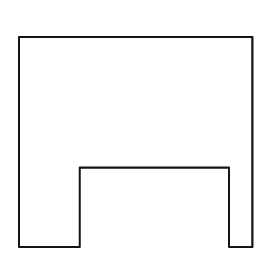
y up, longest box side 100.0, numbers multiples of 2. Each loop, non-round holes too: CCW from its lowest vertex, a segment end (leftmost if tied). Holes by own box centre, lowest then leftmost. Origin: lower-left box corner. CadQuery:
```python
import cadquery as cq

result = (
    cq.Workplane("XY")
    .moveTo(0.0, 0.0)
    .lineTo(26.0, 0.0)
    .lineTo(26.0, 34.0)
    .lineTo(90.0, 34.0)
    .lineTo(90.0, 0.0)
    .lineTo(100.0, 0.0)
    .lineTo(100.0, 90.0)
    .lineTo(0.0, 90.0)
    .close()
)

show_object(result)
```